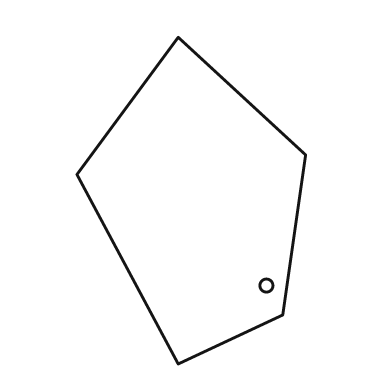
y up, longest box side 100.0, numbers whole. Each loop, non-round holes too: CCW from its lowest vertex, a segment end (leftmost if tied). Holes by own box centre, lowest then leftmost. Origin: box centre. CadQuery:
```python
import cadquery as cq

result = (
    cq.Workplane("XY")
    .moveTo(-4.0, -50.0)
    .lineTo(28.0, -35.0)
    .lineTo(35.0, 14.0)
    .lineTo(-4.0, 50.0)
    .lineTo(-35.0, 8.0)
    .close()
    .moveTo(23.0, -26.0)
    .circle(2.0)
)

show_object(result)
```